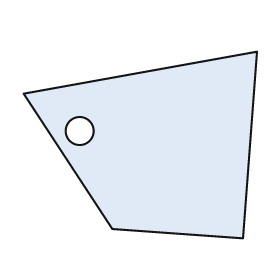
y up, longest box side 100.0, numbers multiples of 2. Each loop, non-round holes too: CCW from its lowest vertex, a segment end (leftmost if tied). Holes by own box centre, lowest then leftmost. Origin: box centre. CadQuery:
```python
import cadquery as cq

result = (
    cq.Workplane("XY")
    .moveTo(44.0, -40.0)
    .lineTo(50.0, 40.0)
    .lineTo(-50.0, 22.0)
    .lineTo(-12.0, -36.0)
    .close()
    .moveTo(-26.0, 6.0)
    .circle(6.0)
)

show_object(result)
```